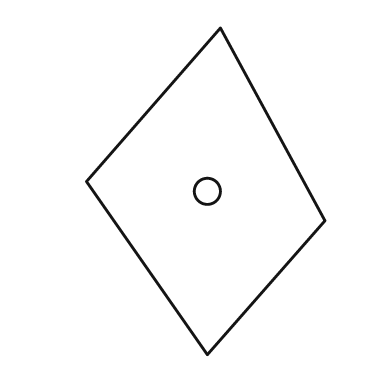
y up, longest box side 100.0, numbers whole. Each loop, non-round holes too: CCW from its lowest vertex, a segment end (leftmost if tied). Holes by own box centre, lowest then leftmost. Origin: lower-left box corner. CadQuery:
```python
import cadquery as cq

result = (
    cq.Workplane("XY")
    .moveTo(37.0, 0.0)
    .lineTo(73.0, 41.0)
    .lineTo(41.0, 100.0)
    .lineTo(0.0, 53.0)
    .close()
    .moveTo(37.0, 50.0)
    .circle(4.0)
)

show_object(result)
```